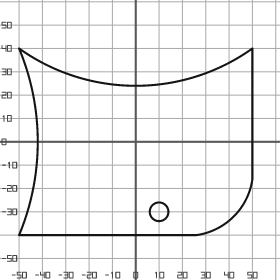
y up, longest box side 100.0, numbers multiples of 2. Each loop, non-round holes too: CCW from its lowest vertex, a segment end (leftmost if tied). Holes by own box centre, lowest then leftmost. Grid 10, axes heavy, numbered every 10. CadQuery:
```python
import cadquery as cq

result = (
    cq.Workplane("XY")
    .moveTo(-50.0, -40.0)
    .lineTo(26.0, -40.0)
    .threePointArc((42.0, -32.0), (50.0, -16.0))
    .lineTo(50.0, 40.0)
    .threePointArc((0.0, 24.0), (-50.0, 40.0))
    .threePointArc((-42.0, 0.0), (-50.0, -40.0))
    .close()
    .moveTo(10.0, -30.0)
    .circle(4.0)
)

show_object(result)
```